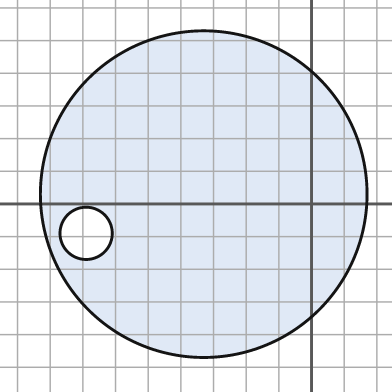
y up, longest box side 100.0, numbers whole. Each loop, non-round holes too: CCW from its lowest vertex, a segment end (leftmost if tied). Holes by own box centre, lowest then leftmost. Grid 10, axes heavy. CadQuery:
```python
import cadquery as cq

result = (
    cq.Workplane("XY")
    .moveTo(-33.0, 3.0)
    .circle(50.0)
    .moveTo(-69.0, -9.0)
    .circle(8.0)
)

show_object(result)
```